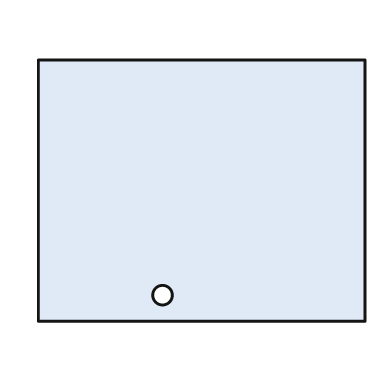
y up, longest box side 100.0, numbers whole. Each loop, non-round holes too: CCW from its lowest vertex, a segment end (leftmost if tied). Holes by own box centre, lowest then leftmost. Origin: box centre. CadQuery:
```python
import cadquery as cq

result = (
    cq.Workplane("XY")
    .moveTo(-50.0, -40.0)
    .lineTo(50.0, -40.0)
    .lineTo(50.0, 40.0)
    .lineTo(-50.0, 40.0)
    .close()
    .moveTo(-12.0, -32.0)
    .circle(3.0)
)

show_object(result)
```